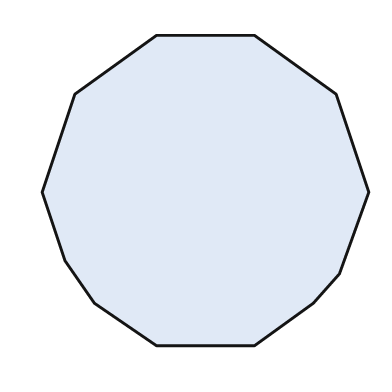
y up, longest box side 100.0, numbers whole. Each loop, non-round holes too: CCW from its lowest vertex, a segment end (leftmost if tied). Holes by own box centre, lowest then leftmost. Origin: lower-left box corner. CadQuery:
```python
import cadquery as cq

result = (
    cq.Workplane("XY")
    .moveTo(35.0, 0.0)
    .lineTo(65.0, 0.0)
    .lineTo(83.0, 13.0)
    .lineTo(91.0, 22.0)
    .lineTo(100.0, 47.0)
    .lineTo(90.0, 77.0)
    .lineTo(65.0, 95.0)
    .lineTo(35.0, 95.0)
    .lineTo(10.0, 77.0)
    .lineTo(0.0, 47.0)
    .lineTo(7.0, 26.0)
    .lineTo(16.0, 13.0)
    .close()
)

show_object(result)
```